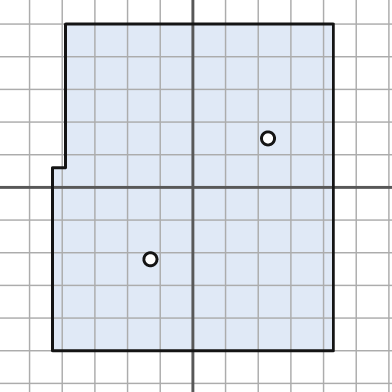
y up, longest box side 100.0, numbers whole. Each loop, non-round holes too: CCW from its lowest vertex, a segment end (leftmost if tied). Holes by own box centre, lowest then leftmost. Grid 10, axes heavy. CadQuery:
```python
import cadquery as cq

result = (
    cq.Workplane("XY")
    .moveTo(-43.0, -50.0)
    .lineTo(43.0, -50.0)
    .lineTo(43.0, 50.0)
    .lineTo(-39.0, 50.0)
    .lineTo(-39.0, 6.0)
    .lineTo(-43.0, 6.0)
    .close()
    .moveTo(-13.0, -22.0)
    .circle(2.0)
    .moveTo(23.0, 15.0)
    .circle(2.0)
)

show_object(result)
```